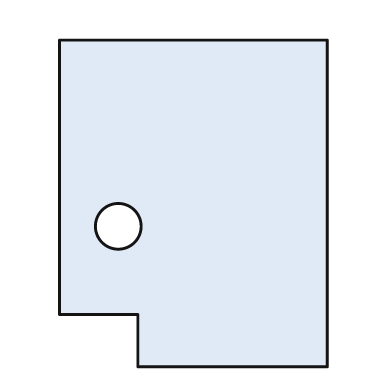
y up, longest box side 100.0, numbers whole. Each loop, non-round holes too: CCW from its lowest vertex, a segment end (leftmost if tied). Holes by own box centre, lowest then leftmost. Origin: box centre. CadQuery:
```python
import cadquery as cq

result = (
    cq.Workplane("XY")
    .moveTo(-17.0, -50.0)
    .lineTo(41.0, -50.0)
    .lineTo(41.0, 50.0)
    .lineTo(-41.0, 50.0)
    .lineTo(-41.0, -34.0)
    .lineTo(-17.0, -34.0)
    .close()
    .moveTo(-23.0, -7.0)
    .circle(7.0)
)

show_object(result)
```